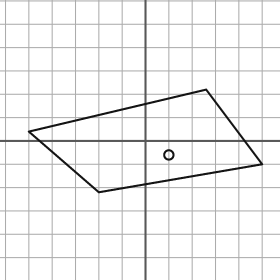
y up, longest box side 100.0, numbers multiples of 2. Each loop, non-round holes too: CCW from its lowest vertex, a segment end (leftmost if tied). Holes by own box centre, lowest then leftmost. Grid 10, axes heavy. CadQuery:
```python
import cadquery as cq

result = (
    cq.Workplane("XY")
    .moveTo(-20.0, -22.0)
    .lineTo(50.0, -10.0)
    .lineTo(26.0, 22.0)
    .lineTo(-50.0, 4.0)
    .close()
    .moveTo(10.0, -6.0)
    .circle(2.0)
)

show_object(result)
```